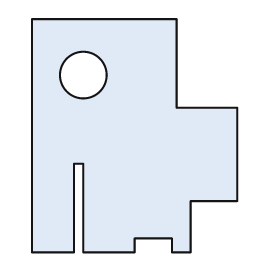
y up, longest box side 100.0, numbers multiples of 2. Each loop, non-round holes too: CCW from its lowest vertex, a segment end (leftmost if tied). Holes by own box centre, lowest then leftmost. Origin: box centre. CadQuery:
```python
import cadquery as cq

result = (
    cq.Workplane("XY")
    .moveTo(-44.0, -50.0)
    .lineTo(-26.0, -50.0)
    .lineTo(-26.0, -12.0)
    .lineTo(-22.0, -12.0)
    .lineTo(-22.0, -50.0)
    .lineTo(0.0, -50.0)
    .lineTo(0.0, -44.0)
    .lineTo(16.0, -44.0)
    .lineTo(16.0, -50.0)
    .lineTo(24.0, -50.0)
    .lineTo(24.0, -28.0)
    .lineTo(44.0, -28.0)
    .lineTo(44.0, 12.0)
    .lineTo(18.0, 12.0)
    .lineTo(18.0, 50.0)
    .lineTo(-44.0, 50.0)
    .close()
    .moveTo(-22.0, 26.0)
    .circle(10.0)
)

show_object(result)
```